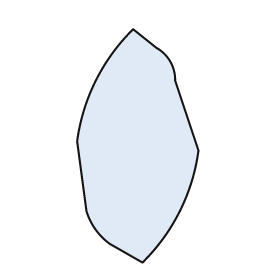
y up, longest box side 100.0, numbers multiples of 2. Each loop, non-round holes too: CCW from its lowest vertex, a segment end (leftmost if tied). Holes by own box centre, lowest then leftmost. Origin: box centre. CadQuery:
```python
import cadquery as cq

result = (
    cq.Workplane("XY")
    .moveTo(2.0, -50.0)
    .threePointArc((18.0, -28.0), (26.0, -2.0))
    .lineTo(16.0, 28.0)
    .threePointArc((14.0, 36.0), (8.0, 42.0))
    .lineTo(-2.0, 50.0)
    .threePointArc((-18.0, 28.0), (-26.0, 2.0))
    .lineTo(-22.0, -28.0)
    .threePointArc((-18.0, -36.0), (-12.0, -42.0))
    .close()
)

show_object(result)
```